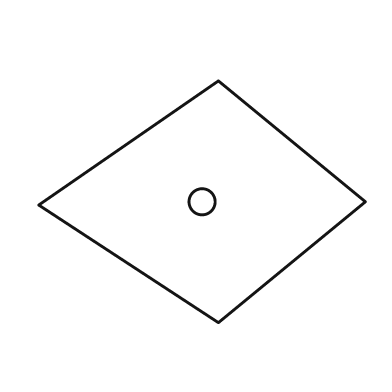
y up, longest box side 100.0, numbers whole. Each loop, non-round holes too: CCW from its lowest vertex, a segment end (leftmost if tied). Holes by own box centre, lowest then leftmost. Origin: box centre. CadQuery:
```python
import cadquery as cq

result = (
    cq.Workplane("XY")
    .moveTo(5.0, -37.0)
    .lineTo(50.0, 0.0)
    .lineTo(5.0, 37.0)
    .lineTo(-50.0, -1.0)
    .close()
    .moveTo(0.0, 0.0)
    .circle(4.0)
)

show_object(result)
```